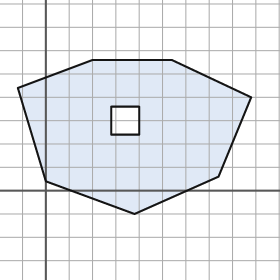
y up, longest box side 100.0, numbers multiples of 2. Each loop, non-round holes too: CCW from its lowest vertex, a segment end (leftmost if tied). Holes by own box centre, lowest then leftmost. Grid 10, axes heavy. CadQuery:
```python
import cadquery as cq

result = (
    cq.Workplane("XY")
    .moveTo(38.0, -10.0)
    .lineTo(74.0, 6.0)
    .lineTo(88.0, 40.0)
    .lineTo(54.0, 56.0)
    .lineTo(20.0, 56.0)
    .lineTo(-12.0, 44.0)
    .lineTo(0.0, 4.0)
    .close()
    .moveTo(28.0, 24.0)
    .lineTo(40.0, 24.0)
    .lineTo(40.0, 36.0)
    .lineTo(28.0, 36.0)
    .close()
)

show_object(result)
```